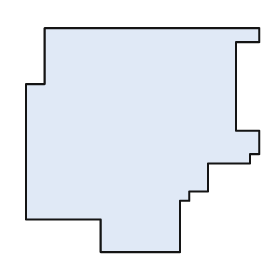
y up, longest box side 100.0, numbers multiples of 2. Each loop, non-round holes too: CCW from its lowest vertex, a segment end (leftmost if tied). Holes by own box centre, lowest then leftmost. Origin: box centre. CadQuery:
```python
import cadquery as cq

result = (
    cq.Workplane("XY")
    .moveTo(-18.0, -48.0)
    .lineTo(16.0, -48.0)
    .lineTo(16.0, -26.0)
    .lineTo(20.0, -26.0)
    .lineTo(20.0, -22.0)
    .lineTo(28.0, -22.0)
    .lineTo(28.0, -10.0)
    .lineTo(46.0, -10.0)
    .lineTo(46.0, -6.0)
    .lineTo(50.0, -6.0)
    .lineTo(50.0, 4.0)
    .lineTo(40.0, 4.0)
    .lineTo(40.0, 42.0)
    .lineTo(50.0, 42.0)
    .lineTo(50.0, 48.0)
    .lineTo(-42.0, 48.0)
    .lineTo(-42.0, 24.0)
    .lineTo(-50.0, 24.0)
    .lineTo(-50.0, -34.0)
    .lineTo(-18.0, -34.0)
    .close()
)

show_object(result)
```